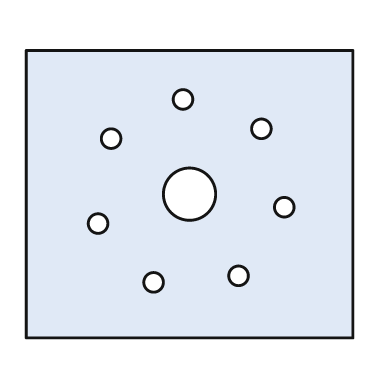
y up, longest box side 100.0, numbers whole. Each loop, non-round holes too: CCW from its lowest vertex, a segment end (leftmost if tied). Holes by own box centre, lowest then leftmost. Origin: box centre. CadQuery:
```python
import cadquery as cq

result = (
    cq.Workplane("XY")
    .moveTo(-50.0, -44.0)
    .lineTo(50.0, -44.0)
    .lineTo(50.0, 44.0)
    .lineTo(-50.0, 44.0)
    .close()
    .moveTo(-11.0, -27.0)
    .circle(3.0)
    .moveTo(15.0, -25.0)
    .circle(3.0)
    .moveTo(-28.0, -9.0)
    .circle(3.0)
    .moveTo(29.0, -4.0)
    .circle(3.0)
    .moveTo(0.0, 0.0)
    .circle(8.0)
    .moveTo(-24.0, 17.0)
    .circle(3.0)
    .moveTo(22.0, 20.0)
    .circle(3.0)
    .moveTo(-2.0, 29.0)
    .circle(3.0)
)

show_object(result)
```